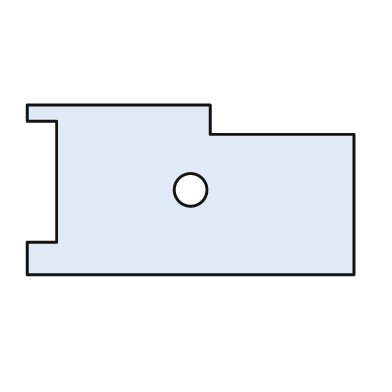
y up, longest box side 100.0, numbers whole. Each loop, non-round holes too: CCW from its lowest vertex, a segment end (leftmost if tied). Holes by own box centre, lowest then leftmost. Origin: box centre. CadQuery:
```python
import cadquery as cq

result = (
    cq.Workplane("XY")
    .moveTo(-50.0, -26.0)
    .lineTo(50.0, -26.0)
    .lineTo(50.0, 17.0)
    .lineTo(6.0, 17.0)
    .lineTo(6.0, 26.0)
    .lineTo(-50.0, 26.0)
    .lineTo(-50.0, 21.0)
    .lineTo(-41.0, 21.0)
    .lineTo(-41.0, -16.0)
    .lineTo(-50.0, -16.0)
    .close()
    .moveTo(0.0, 0.0)
    .circle(5.0)
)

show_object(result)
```